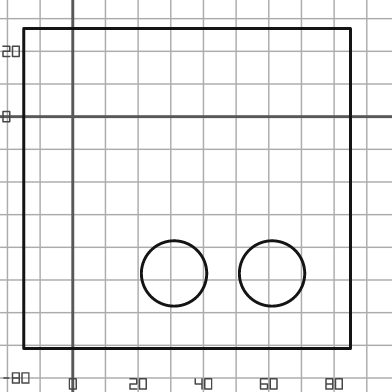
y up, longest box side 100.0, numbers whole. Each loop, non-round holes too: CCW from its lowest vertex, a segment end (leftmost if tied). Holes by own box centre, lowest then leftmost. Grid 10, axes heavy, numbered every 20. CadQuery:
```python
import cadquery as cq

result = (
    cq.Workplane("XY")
    .moveTo(-15.0, -71.0)
    .lineTo(85.0, -71.0)
    .lineTo(85.0, 27.0)
    .lineTo(-15.0, 27.0)
    .close()
    .moveTo(31.0, -48.0)
    .circle(10.0)
    .moveTo(61.0, -48.0)
    .circle(10.0)
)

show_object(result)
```